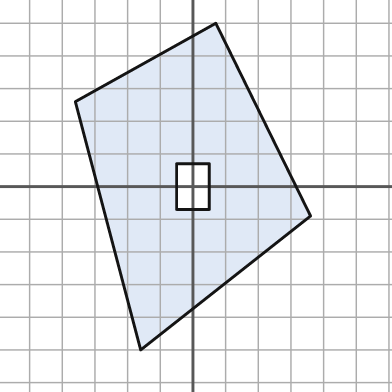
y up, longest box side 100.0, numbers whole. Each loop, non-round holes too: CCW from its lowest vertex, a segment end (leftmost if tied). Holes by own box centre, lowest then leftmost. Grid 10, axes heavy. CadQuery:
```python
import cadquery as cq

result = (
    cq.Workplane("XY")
    .moveTo(-16.0, -50.0)
    .lineTo(36.0, -9.0)
    .lineTo(7.0, 50.0)
    .lineTo(-36.0, 26.0)
    .close()
    .moveTo(-5.0, -7.0)
    .lineTo(5.0, -7.0)
    .lineTo(5.0, 7.0)
    .lineTo(-5.0, 7.0)
    .close()
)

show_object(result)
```